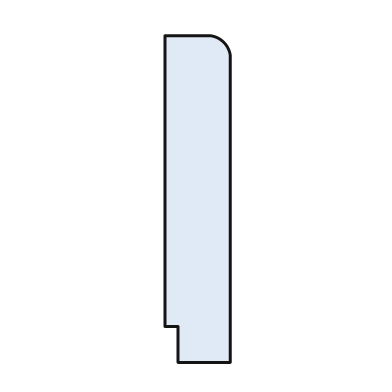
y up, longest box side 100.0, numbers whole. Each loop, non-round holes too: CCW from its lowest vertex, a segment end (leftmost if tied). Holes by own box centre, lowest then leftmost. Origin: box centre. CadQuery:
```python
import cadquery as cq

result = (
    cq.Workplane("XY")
    .moveTo(-6.0, -50.0)
    .lineTo(10.0, -50.0)
    .lineTo(10.0, 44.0)
    .threePointArc((8.0, 48.0), (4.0, 50.0))
    .lineTo(-10.0, 50.0)
    .lineTo(-10.0, -39.0)
    .lineTo(-6.0, -39.0)
    .close()
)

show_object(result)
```